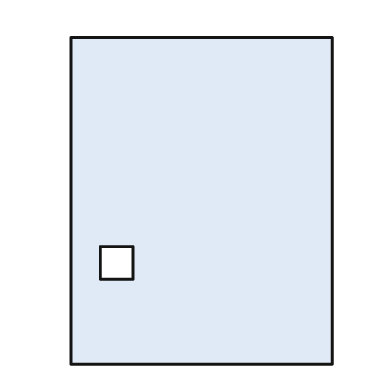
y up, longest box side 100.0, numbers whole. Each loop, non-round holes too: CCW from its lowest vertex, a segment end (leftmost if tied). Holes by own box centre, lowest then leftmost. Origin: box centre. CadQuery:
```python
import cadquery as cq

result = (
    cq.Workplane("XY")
    .moveTo(-40.0, -50.0)
    .lineTo(40.0, -50.0)
    .lineTo(40.0, 50.0)
    .lineTo(-40.0, 50.0)
    .close()
    .moveTo(-31.0, -24.0)
    .lineTo(-21.0, -24.0)
    .lineTo(-21.0, -14.0)
    .lineTo(-31.0, -14.0)
    .close()
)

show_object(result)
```